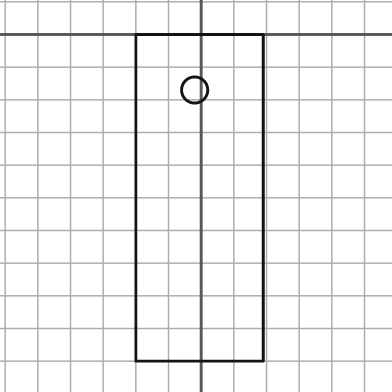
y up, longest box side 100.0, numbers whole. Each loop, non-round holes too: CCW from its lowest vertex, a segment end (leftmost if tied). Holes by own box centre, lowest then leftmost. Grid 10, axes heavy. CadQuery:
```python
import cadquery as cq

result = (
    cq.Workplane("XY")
    .moveTo(-20.0, -100.0)
    .lineTo(19.0, -100.0)
    .lineTo(19.0, 0.0)
    .lineTo(-20.0, 0.0)
    .close()
    .moveTo(-2.0, -17.0)
    .circle(4.0)
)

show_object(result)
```